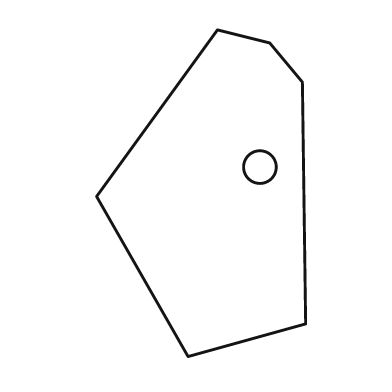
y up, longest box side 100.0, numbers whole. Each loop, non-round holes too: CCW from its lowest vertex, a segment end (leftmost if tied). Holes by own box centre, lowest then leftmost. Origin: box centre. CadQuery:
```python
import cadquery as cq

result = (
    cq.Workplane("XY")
    .moveTo(-4.0, -50.0)
    .lineTo(32.0, -40.0)
    .lineTo(31.0, 34.0)
    .lineTo(21.0, 46.0)
    .lineTo(5.0, 50.0)
    .lineTo(-32.0, -1.0)
    .close()
    .moveTo(18.0, 8.0)
    .circle(5.0)
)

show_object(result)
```